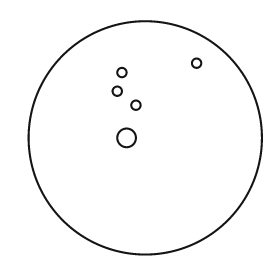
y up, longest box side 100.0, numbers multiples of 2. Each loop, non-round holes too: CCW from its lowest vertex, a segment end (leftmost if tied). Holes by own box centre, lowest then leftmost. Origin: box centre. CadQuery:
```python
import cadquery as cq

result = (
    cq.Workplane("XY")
    .moveTo(0.0, 0.0)
    .circle(50.0)
    .moveTo(-8.0, 0.0)
    .circle(4.0)
    .moveTo(-4.0, 14.0)
    .circle(2.0)
    .moveTo(-12.0, 20.0)
    .circle(2.0)
    .moveTo(-10.0, 28.0)
    .circle(2.0)
    .moveTo(22.0, 32.0)
    .circle(2.0)
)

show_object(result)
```